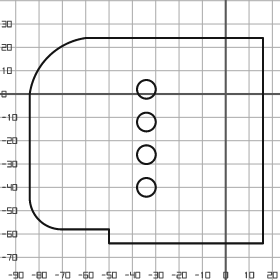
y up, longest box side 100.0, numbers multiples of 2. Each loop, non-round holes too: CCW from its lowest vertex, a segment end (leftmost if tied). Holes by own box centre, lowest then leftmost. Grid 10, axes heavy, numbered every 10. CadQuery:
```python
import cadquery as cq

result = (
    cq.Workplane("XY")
    .moveTo(-50.0, -64.0)
    .lineTo(16.0, -64.0)
    .lineTo(16.0, 24.0)
    .lineTo(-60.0, 24.0)
    .threePointArc((-76.0, 16.0), (-84.0, 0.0))
    .lineTo(-84.0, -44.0)
    .threePointArc((-80.0, -54.0), (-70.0, -58.0))
    .lineTo(-50.0, -58.0)
    .close()
    .moveTo(-34.0, -40.0)
    .circle(4.0)
    .moveTo(-34.0, -26.0)
    .circle(4.0)
    .moveTo(-34.0, -12.0)
    .circle(4.0)
    .moveTo(-34.0, 2.0)
    .circle(4.0)
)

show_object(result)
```